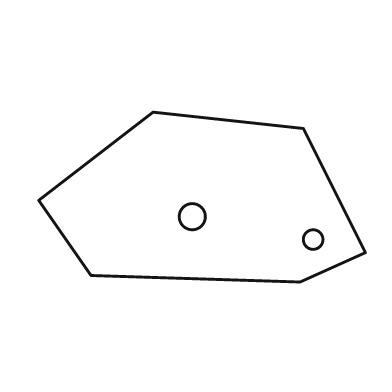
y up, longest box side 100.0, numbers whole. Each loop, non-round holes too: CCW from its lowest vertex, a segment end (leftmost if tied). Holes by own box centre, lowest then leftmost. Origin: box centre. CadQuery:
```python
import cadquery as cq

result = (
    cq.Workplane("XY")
    .moveTo(30.0, -26.0)
    .lineTo(50.0, -17.0)
    .lineTo(31.0, 21.0)
    .lineTo(-15.0, 26.0)
    .lineTo(-50.0, -1.0)
    .lineTo(-34.0, -24.0)
    .close()
    .moveTo(34.0, -13.0)
    .circle(3.0)
    .moveTo(-3.0, -6.0)
    .circle(4.0)
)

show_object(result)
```